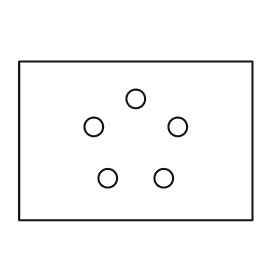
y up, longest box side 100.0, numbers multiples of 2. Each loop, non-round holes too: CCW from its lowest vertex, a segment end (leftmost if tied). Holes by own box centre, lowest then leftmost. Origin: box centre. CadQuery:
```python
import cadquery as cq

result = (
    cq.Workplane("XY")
    .moveTo(-50.0, -34.0)
    .lineTo(50.0, -34.0)
    .lineTo(50.0, 34.0)
    .lineTo(-50.0, 34.0)
    .close()
    .moveTo(-12.0, -16.0)
    .circle(4.0)
    .moveTo(12.0, -16.0)
    .circle(4.0)
    .moveTo(-18.0, 6.0)
    .circle(4.0)
    .moveTo(18.0, 6.0)
    .circle(4.0)
    .moveTo(0.0, 18.0)
    .circle(4.0)
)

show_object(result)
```